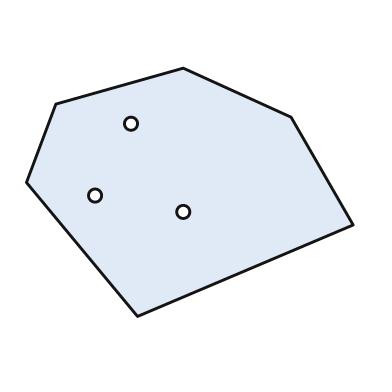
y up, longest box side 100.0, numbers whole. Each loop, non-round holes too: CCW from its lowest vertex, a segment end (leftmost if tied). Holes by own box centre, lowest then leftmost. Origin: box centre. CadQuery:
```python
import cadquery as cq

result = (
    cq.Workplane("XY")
    .moveTo(-16.0, -38.0)
    .lineTo(50.0, -10.0)
    .lineTo(31.0, 23.0)
    .lineTo(-2.0, 38.0)
    .lineTo(-41.0, 27.0)
    .lineTo(-50.0, 3.0)
    .close()
    .moveTo(-2.0, -6.0)
    .circle(2.0)
    .moveTo(-29.0, -1.0)
    .circle(2.0)
    .moveTo(-18.0, 21.0)
    .circle(2.0)
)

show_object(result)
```